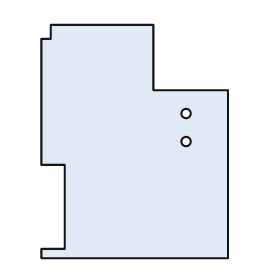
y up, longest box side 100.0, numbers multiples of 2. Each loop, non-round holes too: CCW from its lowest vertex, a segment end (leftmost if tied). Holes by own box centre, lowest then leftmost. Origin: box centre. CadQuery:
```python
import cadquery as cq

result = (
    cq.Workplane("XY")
    .moveTo(-40.0, -50.0)
    .lineTo(40.0, -50.0)
    .lineTo(40.0, 22.0)
    .lineTo(8.0, 22.0)
    .lineTo(8.0, 50.0)
    .lineTo(-36.0, 50.0)
    .lineTo(-36.0, 44.0)
    .lineTo(-40.0, 44.0)
    .lineTo(-40.0, -10.0)
    .lineTo(-30.0, -10.0)
    .lineTo(-30.0, -46.0)
    .lineTo(-40.0, -46.0)
    .close()
    .moveTo(22.0, 0.0)
    .circle(2.0)
    .moveTo(22.0, 12.0)
    .circle(2.0)
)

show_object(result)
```